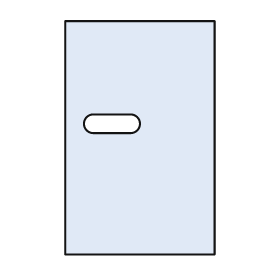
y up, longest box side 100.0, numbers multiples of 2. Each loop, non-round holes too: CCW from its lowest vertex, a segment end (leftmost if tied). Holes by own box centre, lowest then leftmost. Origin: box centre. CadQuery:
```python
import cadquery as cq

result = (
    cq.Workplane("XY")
    .moveTo(-32.0, -50.0)
    .lineTo(32.0, -50.0)
    .lineTo(32.0, 50.0)
    .lineTo(-32.0, 50.0)
    .close()
    .moveTo(-20.0, 2.0)
    .lineTo(-4.0, 2.0)
    .threePointArc((0.0, 6.0), (-4.0, 10.0))
    .lineTo(-20.0, 10.0)
    .threePointArc((-24.0, 6.0), (-20.0, 2.0))
    .close()
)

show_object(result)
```